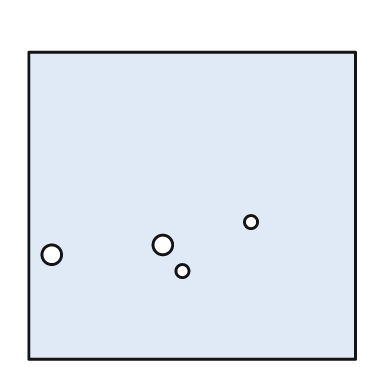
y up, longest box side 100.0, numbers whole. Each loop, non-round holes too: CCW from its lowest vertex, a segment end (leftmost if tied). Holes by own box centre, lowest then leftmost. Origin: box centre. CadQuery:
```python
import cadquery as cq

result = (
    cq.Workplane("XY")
    .moveTo(-50.0, -47.0)
    .lineTo(50.0, -47.0)
    .lineTo(50.0, 47.0)
    .lineTo(-50.0, 47.0)
    .close()
    .moveTo(-3.0, -20.0)
    .circle(2.0)
    .moveTo(-43.0, -15.0)
    .circle(3.0)
    .moveTo(-9.0, -12.0)
    .circle(3.0)
    .moveTo(18.0, -5.0)
    .circle(2.0)
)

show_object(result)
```